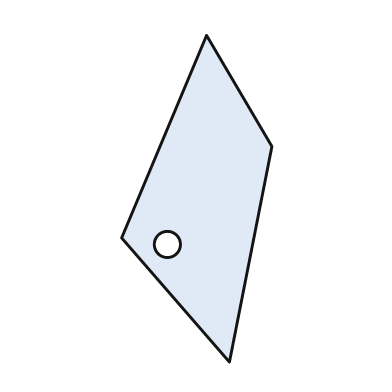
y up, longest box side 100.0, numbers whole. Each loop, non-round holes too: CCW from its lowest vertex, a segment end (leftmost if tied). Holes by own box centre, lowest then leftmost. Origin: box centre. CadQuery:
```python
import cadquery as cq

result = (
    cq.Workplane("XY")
    .moveTo(10.0, -50.0)
    .lineTo(23.0, 16.0)
    .lineTo(3.0, 50.0)
    .lineTo(-23.0, -12.0)
    .close()
    .moveTo(-9.0, -14.0)
    .circle(4.0)
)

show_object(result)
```